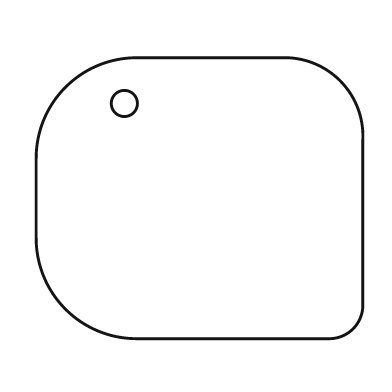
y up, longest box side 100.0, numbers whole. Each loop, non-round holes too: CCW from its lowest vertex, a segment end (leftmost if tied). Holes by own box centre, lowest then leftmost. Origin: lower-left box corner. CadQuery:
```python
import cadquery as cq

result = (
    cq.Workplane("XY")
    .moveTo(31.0, 0.0)
    .lineTo(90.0, 0.0)
    .threePointArc((97.0, 3.0), (100.0, 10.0))
    .lineTo(100.0, 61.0)
    .threePointArc((93.0, 79.0), (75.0, 86.0))
    .lineTo(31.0, 86.0)
    .threePointArc((9.0, 77.0), (0.0, 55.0))
    .lineTo(0.0, 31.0)
    .threePointArc((9.0, 9.0), (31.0, 0.0))
    .close()
    .moveTo(27.0, 72.0)
    .circle(4.0)
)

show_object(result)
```